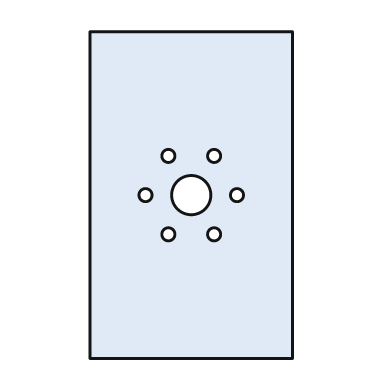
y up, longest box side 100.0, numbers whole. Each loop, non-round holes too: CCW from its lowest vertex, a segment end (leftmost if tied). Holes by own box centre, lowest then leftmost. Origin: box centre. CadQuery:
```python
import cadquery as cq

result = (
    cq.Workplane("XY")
    .moveTo(-31.0, -50.0)
    .lineTo(31.0, -50.0)
    .lineTo(31.0, 50.0)
    .lineTo(-31.0, 50.0)
    .close()
    .moveTo(-7.0, -12.0)
    .circle(2.0)
    .moveTo(7.0, -12.0)
    .circle(2.0)
    .moveTo(-14.0, 0.0)
    .circle(2.0)
    .moveTo(0.0, 0.0)
    .circle(6.0)
    .moveTo(14.0, 0.0)
    .circle(2.0)
    .moveTo(-7.0, 12.0)
    .circle(2.0)
    .moveTo(7.0, 12.0)
    .circle(2.0)
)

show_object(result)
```